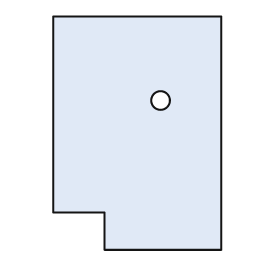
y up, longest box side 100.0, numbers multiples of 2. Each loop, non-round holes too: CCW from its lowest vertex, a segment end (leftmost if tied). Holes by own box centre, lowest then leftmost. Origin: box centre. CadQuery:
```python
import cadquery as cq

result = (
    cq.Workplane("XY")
    .moveTo(-14.0, -50.0)
    .lineTo(36.0, -50.0)
    .lineTo(36.0, 50.0)
    .lineTo(-36.0, 50.0)
    .lineTo(-36.0, -34.0)
    .lineTo(-14.0, -34.0)
    .close()
    .moveTo(10.0, 14.0)
    .circle(4.0)
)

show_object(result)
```